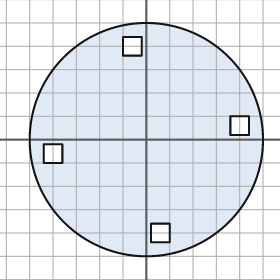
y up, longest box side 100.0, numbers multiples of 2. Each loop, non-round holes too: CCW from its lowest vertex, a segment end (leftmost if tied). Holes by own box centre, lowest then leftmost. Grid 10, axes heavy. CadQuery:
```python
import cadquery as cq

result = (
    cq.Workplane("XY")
    .moveTo(0.0, 0.0)
    .circle(50.0)
    .moveTo(2.0, -44.0)
    .lineTo(10.0, -44.0)
    .lineTo(10.0, -36.0)
    .lineTo(2.0, -36.0)
    .close()
    .moveTo(-44.0, -10.0)
    .lineTo(-36.0, -10.0)
    .lineTo(-36.0, -2.0)
    .lineTo(-44.0, -2.0)
    .close()
    .moveTo(36.0, 2.0)
    .lineTo(44.0, 2.0)
    .lineTo(44.0, 10.0)
    .lineTo(36.0, 10.0)
    .close()
    .moveTo(-10.0, 36.0)
    .lineTo(-2.0, 36.0)
    .lineTo(-2.0, 44.0)
    .lineTo(-10.0, 44.0)
    .close()
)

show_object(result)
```